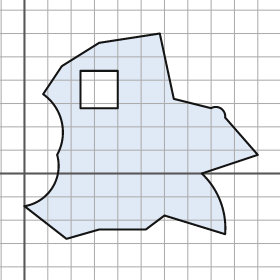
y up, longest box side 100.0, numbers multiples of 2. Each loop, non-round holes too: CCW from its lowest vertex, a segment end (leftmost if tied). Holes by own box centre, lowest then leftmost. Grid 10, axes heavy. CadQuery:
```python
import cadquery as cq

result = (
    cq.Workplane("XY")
    .moveTo(18.0, -28.0)
    .lineTo(32.0, -24.0)
    .lineTo(52.0, -24.0)
    .lineTo(60.0, -18.0)
    .lineTo(86.0, -26.0)
    .threePointArc((84.0, -12.0), (76.0, 0.0))
    .lineTo(100.0, 8.0)
    .lineTo(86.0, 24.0)
    .threePointArc((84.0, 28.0), (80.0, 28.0))
    .lineTo(64.0, 32.0)
    .lineTo(58.0, 60.0)
    .lineTo(32.0, 56.0)
    .lineTo(16.0, 46.0)
    .lineTo(8.0, 34.0)
    .threePointArc((16.0, 22.0), (14.0, 8.0))
    .threePointArc((12.0, -6.0), (0.0, -14.0))
    .close()
    .moveTo(24.0, 28.0)
    .lineTo(40.0, 28.0)
    .lineTo(40.0, 44.0)
    .lineTo(24.0, 44.0)
    .close()
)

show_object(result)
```